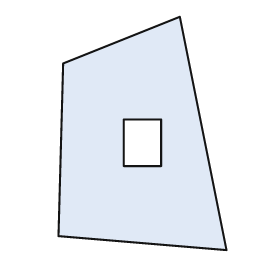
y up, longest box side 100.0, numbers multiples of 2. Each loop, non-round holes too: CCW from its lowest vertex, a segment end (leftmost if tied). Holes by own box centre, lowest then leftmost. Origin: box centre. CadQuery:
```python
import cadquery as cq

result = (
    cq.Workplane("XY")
    .moveTo(36.0, -50.0)
    .lineTo(16.0, 50.0)
    .lineTo(-34.0, 30.0)
    .lineTo(-36.0, -44.0)
    .close()
    .moveTo(-8.0, -14.0)
    .lineTo(8.0, -14.0)
    .lineTo(8.0, 6.0)
    .lineTo(-8.0, 6.0)
    .close()
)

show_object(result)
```